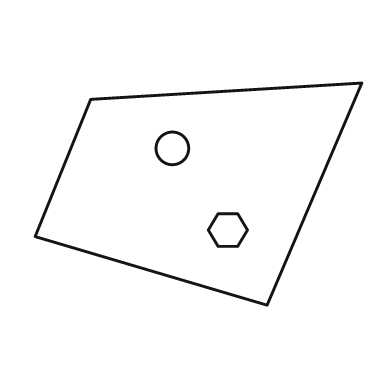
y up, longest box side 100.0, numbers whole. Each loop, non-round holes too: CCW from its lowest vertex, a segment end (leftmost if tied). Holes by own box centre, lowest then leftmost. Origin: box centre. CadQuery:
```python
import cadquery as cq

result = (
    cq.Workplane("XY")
    .moveTo(21.0, -34.0)
    .lineTo(50.0, 34.0)
    .lineTo(-33.0, 29.0)
    .lineTo(-50.0, -13.0)
    .close()
    .moveTo(6.0, -16.0)
    .lineTo(12.0, -16.0)
    .lineTo(15.0, -11.0)
    .lineTo(12.0, -6.0)
    .lineTo(6.0, -6.0)
    .lineTo(3.0, -11.0)
    .close()
    .moveTo(-8.0, 14.0)
    .circle(5.0)
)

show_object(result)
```